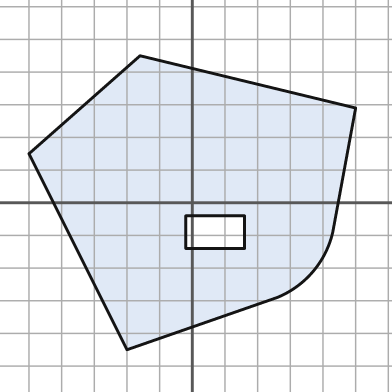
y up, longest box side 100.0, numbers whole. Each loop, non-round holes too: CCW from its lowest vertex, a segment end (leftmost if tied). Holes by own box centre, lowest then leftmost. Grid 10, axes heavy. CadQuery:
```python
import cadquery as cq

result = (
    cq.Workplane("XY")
    .moveTo(-20.0, -45.0)
    .lineTo(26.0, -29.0)
    .threePointArc((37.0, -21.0), (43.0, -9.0))
    .lineTo(50.0, 29.0)
    .lineTo(-16.0, 45.0)
    .lineTo(-50.0, 15.0)
    .close()
    .moveTo(-2.0, -14.0)
    .lineTo(16.0, -14.0)
    .lineTo(16.0, -4.0)
    .lineTo(-2.0, -4.0)
    .close()
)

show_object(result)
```